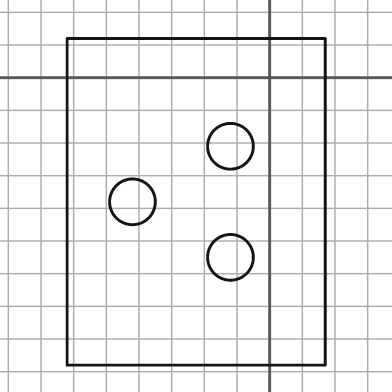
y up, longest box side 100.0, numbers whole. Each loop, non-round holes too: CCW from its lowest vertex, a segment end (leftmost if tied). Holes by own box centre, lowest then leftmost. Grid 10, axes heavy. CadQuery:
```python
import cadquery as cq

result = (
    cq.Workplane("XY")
    .moveTo(-62.0, -88.0)
    .lineTo(17.0, -88.0)
    .lineTo(17.0, 12.0)
    .lineTo(-62.0, 12.0)
    .close()
    .moveTo(-12.0, -55.0)
    .circle(7.0)
    .moveTo(-42.0, -38.0)
    .circle(7.0)
    .moveTo(-12.0, -21.0)
    .circle(7.0)
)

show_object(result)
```